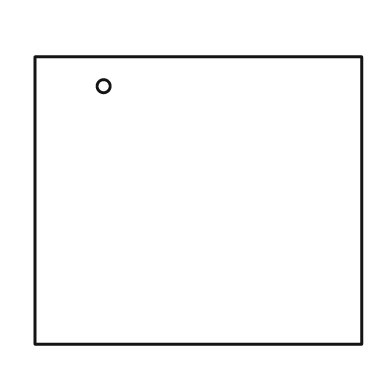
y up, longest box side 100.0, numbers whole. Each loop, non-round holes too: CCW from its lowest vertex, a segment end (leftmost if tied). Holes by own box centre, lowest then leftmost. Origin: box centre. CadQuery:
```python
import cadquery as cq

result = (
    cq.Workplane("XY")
    .moveTo(-50.0, -44.0)
    .lineTo(50.0, -44.0)
    .lineTo(50.0, 44.0)
    .lineTo(-50.0, 44.0)
    .close()
    .moveTo(-29.0, 35.0)
    .circle(2.0)
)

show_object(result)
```